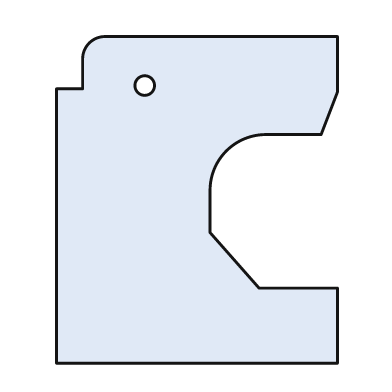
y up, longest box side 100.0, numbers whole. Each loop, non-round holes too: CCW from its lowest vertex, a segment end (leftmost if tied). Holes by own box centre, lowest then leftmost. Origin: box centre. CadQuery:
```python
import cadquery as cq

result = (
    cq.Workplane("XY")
    .moveTo(-43.0, -50.0)
    .lineTo(43.0, -50.0)
    .lineTo(43.0, -27.0)
    .lineTo(19.0, -27.0)
    .lineTo(4.0, -10.0)
    .lineTo(4.0, 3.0)
    .threePointArc((9.0, 15.0), (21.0, 20.0))
    .lineTo(38.0, 20.0)
    .lineTo(43.0, 33.0)
    .lineTo(43.0, 50.0)
    .lineTo(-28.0, 50.0)
    .threePointArc((-33.0, 48.0), (-35.0, 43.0))
    .lineTo(-35.0, 34.0)
    .lineTo(-43.0, 34.0)
    .close()
    .moveTo(-16.0, 35.0)
    .circle(3.0)
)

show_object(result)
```